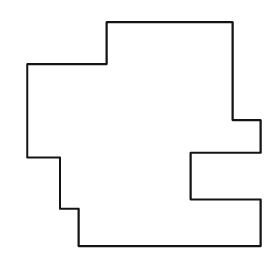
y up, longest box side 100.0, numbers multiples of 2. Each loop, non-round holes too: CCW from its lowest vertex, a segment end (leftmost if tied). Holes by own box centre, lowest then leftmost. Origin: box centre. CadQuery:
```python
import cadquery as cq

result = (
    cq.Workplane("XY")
    .moveTo(-28.0, -48.0)
    .lineTo(50.0, -48.0)
    .lineTo(50.0, -28.0)
    .lineTo(20.0, -28.0)
    .lineTo(20.0, -8.0)
    .lineTo(50.0, -8.0)
    .lineTo(50.0, 6.0)
    .lineTo(38.0, 6.0)
    .lineTo(38.0, 48.0)
    .lineTo(-16.0, 48.0)
    .lineTo(-16.0, 30.0)
    .lineTo(-50.0, 30.0)
    .lineTo(-50.0, -10.0)
    .lineTo(-36.0, -10.0)
    .lineTo(-36.0, -32.0)
    .lineTo(-28.0, -32.0)
    .close()
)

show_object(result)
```